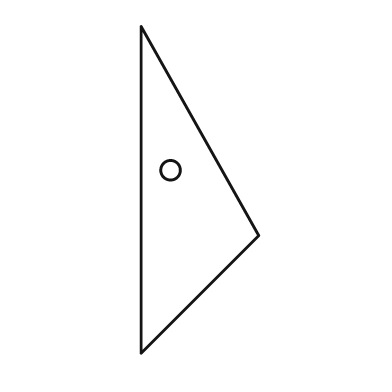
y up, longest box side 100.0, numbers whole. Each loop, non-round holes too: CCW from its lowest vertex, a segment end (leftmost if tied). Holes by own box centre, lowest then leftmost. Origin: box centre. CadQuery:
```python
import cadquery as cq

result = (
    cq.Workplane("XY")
    .moveTo(-18.0, -50.0)
    .lineTo(18.0, -14.0)
    .lineTo(-18.0, 50.0)
    .close()
    .moveTo(-9.0, 6.0)
    .circle(3.0)
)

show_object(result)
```